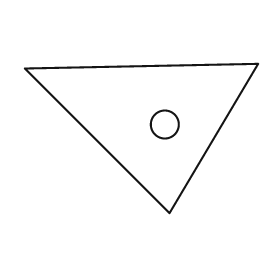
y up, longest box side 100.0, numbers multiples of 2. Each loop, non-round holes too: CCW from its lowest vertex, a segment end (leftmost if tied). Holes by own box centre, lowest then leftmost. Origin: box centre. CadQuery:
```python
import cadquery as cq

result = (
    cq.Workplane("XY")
    .moveTo(12.0, -32.0)
    .lineTo(50.0, 32.0)
    .lineTo(-50.0, 30.0)
    .close()
    .moveTo(10.0, 6.0)
    .circle(6.0)
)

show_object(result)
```